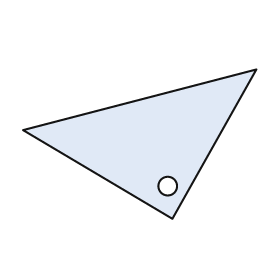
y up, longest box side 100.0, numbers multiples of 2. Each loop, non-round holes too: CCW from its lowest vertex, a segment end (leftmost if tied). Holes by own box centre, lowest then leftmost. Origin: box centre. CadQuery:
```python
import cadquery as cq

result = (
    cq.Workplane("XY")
    .moveTo(14.0, -32.0)
    .lineTo(50.0, 32.0)
    .lineTo(-50.0, 6.0)
    .close()
    .moveTo(12.0, -18.0)
    .circle(4.0)
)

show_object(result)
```